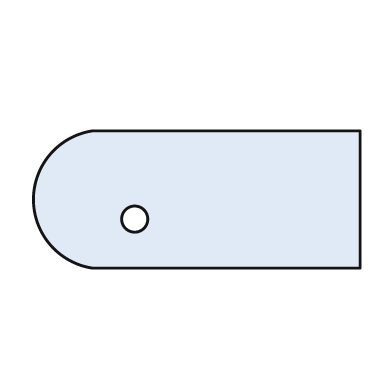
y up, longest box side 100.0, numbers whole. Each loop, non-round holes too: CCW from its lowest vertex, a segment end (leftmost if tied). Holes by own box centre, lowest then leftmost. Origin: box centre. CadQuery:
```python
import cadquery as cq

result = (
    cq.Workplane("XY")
    .moveTo(-32.0, -21.0)
    .lineTo(50.0, -21.0)
    .lineTo(50.0, 21.0)
    .lineTo(-32.0, 21.0)
    .threePointArc((-50.0, 0.0), (-32.0, -21.0))
    .close()
    .moveTo(-19.0, -6.0)
    .circle(4.0)
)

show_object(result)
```